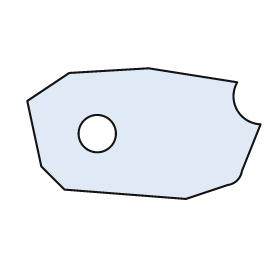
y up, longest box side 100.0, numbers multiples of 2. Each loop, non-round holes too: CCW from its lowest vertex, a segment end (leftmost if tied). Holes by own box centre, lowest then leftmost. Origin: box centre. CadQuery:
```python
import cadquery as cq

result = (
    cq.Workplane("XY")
    .moveTo(18.0, -28.0)
    .lineTo(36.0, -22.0)
    .threePointArc((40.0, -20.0), (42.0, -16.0))
    .lineTo(50.0, 4.0)
    .threePointArc((40.0, 10.0), (40.0, 22.0))
    .lineTo(2.0, 28.0)
    .lineTo(-32.0, 26.0)
    .lineTo(-50.0, 14.0)
    .lineTo(-44.0, -14.0)
    .lineTo(-34.0, -24.0)
    .close()
    .moveTo(-20.0, 0.0)
    .circle(8.0)
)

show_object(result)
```